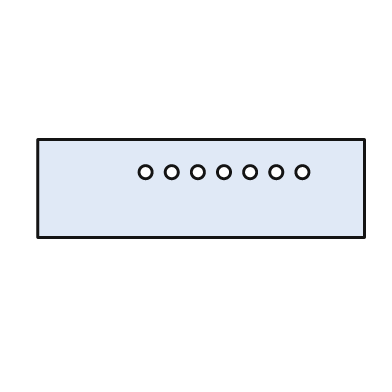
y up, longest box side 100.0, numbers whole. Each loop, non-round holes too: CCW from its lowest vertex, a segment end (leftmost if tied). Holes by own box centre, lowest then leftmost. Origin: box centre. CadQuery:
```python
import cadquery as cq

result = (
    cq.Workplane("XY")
    .moveTo(-50.0, -15.0)
    .lineTo(50.0, -15.0)
    .lineTo(50.0, 15.0)
    .lineTo(-50.0, 15.0)
    .close()
    .moveTo(-17.0, 5.0)
    .circle(2.0)
    .moveTo(-9.0, 5.0)
    .circle(2.0)
    .moveTo(-1.0, 5.0)
    .circle(2.0)
    .moveTo(7.0, 5.0)
    .circle(2.0)
    .moveTo(15.0, 5.0)
    .circle(2.0)
    .moveTo(23.0, 5.0)
    .circle(2.0)
    .moveTo(31.0, 5.0)
    .circle(2.0)
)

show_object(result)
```